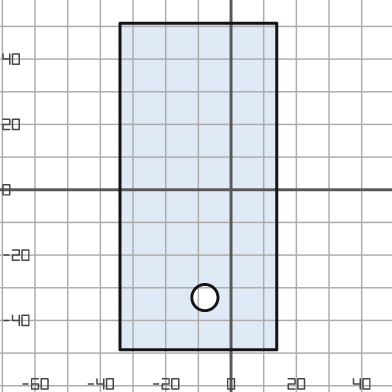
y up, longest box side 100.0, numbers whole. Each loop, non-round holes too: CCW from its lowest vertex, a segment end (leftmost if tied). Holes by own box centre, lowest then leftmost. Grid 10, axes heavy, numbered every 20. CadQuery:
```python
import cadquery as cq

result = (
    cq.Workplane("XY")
    .moveTo(-34.0, -49.0)
    .lineTo(14.0, -49.0)
    .lineTo(14.0, 51.0)
    .lineTo(-34.0, 51.0)
    .close()
    .moveTo(-8.0, -33.0)
    .circle(4.0)
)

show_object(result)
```